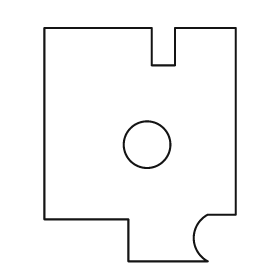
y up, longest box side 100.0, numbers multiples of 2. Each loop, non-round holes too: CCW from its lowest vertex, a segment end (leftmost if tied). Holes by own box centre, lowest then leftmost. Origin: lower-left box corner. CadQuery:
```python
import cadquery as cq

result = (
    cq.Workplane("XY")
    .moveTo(36.0, 0.0)
    .lineTo(70.0, 0.0)
    .threePointArc((64.0, 10.0), (70.0, 20.0))
    .lineTo(82.0, 20.0)
    .lineTo(82.0, 100.0)
    .lineTo(56.0, 100.0)
    .lineTo(56.0, 84.0)
    .lineTo(46.0, 84.0)
    .lineTo(46.0, 100.0)
    .lineTo(0.0, 100.0)
    .lineTo(0.0, 18.0)
    .lineTo(36.0, 18.0)
    .close()
    .moveTo(44.0, 50.0)
    .circle(10.0)
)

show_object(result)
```